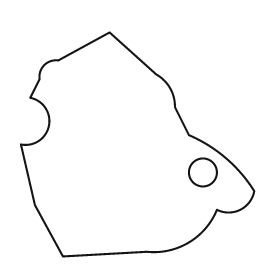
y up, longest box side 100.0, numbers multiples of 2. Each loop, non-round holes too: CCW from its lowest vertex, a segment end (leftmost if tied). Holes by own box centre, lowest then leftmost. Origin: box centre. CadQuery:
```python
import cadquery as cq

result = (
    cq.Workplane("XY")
    .moveTo(-32.0, -48.0)
    .lineTo(4.0, -46.0)
    .threePointArc((22.0, -42.0), (34.0, -28.0))
    .threePointArc((44.0, -28.0), (50.0, -20.0))
    .threePointArc((38.0, -6.0), (22.0, 4.0))
    .lineTo(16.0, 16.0)
    .threePointArc((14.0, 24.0), (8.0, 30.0))
    .lineTo(-12.0, 48.0)
    .lineTo(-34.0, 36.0)
    .threePointArc((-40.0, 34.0), (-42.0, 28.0))
    .lineTo(-46.0, 20.0)
    .threePointArc((-38.0, 8.0), (-50.0, 0.0))
    .lineTo(-44.0, -26.0)
    .close()
    .moveTo(28.0, -12.0)
    .circle(6.0)
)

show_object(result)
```